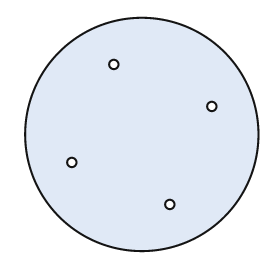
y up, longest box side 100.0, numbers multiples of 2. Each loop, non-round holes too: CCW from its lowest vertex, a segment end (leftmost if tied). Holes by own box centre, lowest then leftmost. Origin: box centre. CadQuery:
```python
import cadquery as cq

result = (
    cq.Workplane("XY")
    .moveTo(0.0, 0.0)
    .circle(50.0)
    .moveTo(12.0, -30.0)
    .circle(2.0)
    .moveTo(-30.0, -12.0)
    .circle(2.0)
    .moveTo(30.0, 12.0)
    .circle(2.0)
    .moveTo(-12.0, 30.0)
    .circle(2.0)
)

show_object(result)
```